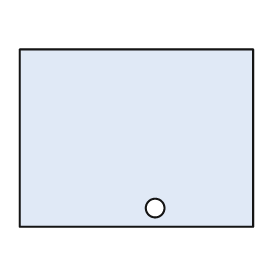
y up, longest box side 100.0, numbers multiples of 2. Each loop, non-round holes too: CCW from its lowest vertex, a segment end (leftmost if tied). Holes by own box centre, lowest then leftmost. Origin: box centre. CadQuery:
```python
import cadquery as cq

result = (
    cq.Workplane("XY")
    .moveTo(-50.0, -38.0)
    .lineTo(50.0, -38.0)
    .lineTo(50.0, 38.0)
    .lineTo(-50.0, 38.0)
    .close()
    .moveTo(8.0, -30.0)
    .circle(4.0)
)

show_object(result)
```